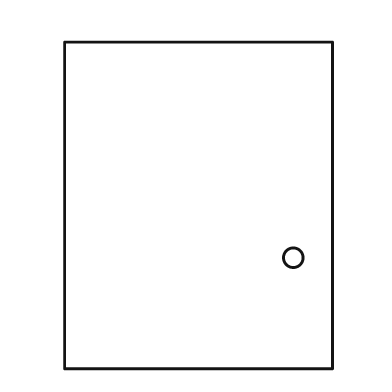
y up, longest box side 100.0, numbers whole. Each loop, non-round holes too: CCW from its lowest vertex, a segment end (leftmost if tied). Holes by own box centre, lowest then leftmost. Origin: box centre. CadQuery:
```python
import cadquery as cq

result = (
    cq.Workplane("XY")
    .moveTo(-41.0, -50.0)
    .lineTo(41.0, -50.0)
    .lineTo(41.0, 50.0)
    .lineTo(-41.0, 50.0)
    .close()
    .moveTo(29.0, -16.0)
    .circle(3.0)
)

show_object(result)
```